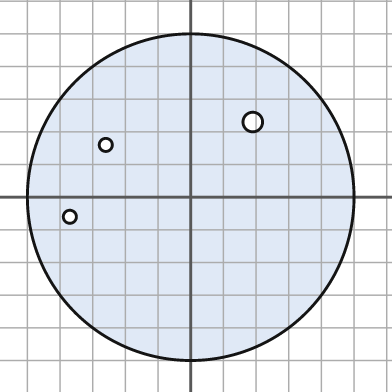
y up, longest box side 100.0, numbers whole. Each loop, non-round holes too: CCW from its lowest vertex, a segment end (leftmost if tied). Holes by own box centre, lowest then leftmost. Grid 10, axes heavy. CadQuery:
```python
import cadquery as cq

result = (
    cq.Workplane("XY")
    .moveTo(0.0, 0.0)
    .circle(50.0)
    .moveTo(-37.0, -6.0)
    .circle(2.0)
    .moveTo(-26.0, 16.0)
    .circle(2.0)
    .moveTo(19.0, 23.0)
    .circle(3.0)
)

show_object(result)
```